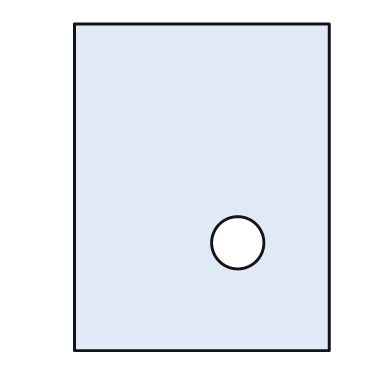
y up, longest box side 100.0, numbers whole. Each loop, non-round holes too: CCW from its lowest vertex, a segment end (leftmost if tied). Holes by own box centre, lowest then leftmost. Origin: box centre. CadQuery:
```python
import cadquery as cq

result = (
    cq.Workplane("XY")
    .moveTo(-39.0, -50.0)
    .lineTo(39.0, -50.0)
    .lineTo(39.0, 50.0)
    .lineTo(-39.0, 50.0)
    .close()
    .moveTo(11.0, -17.0)
    .circle(8.0)
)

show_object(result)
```